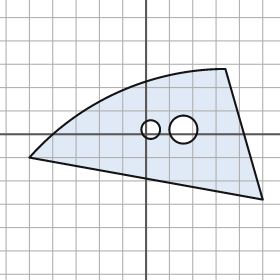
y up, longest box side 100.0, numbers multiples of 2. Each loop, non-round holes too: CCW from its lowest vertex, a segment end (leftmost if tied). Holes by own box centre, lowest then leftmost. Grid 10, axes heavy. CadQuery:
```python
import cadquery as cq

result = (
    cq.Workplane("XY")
    .moveTo(50.0, -28.0)
    .lineTo(34.0, 28.0)
    .threePointArc((-12.0, 18.0), (-50.0, -10.0))
    .close()
    .moveTo(2.0, 2.0)
    .circle(4.0)
    .moveTo(16.0, 2.0)
    .circle(6.0)
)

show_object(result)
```